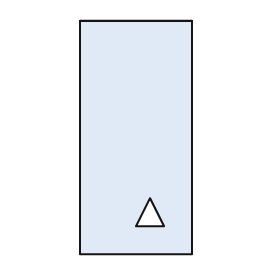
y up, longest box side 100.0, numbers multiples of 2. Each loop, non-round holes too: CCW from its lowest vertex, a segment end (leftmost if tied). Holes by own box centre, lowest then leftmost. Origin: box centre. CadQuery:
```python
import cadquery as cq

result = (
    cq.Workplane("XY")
    .moveTo(-24.0, -50.0)
    .lineTo(24.0, -50.0)
    .lineTo(24.0, 50.0)
    .lineTo(-24.0, 50.0)
    .close()
    .moveTo(0.0, -38.0)
    .lineTo(12.0, -38.0)
    .lineTo(6.0, -26.0)
    .close()
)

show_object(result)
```